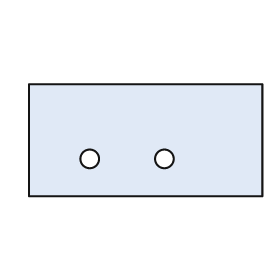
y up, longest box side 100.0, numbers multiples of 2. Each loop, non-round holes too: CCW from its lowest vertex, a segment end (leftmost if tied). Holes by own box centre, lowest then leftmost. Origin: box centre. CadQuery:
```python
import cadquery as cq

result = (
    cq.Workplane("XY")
    .moveTo(-50.0, -24.0)
    .lineTo(50.0, -24.0)
    .lineTo(50.0, 24.0)
    .lineTo(-50.0, 24.0)
    .close()
    .moveTo(-24.0, -8.0)
    .circle(4.0)
    .moveTo(8.0, -8.0)
    .circle(4.0)
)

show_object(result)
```